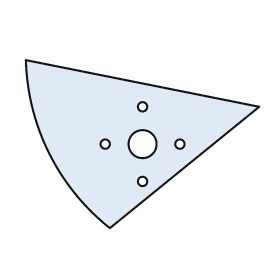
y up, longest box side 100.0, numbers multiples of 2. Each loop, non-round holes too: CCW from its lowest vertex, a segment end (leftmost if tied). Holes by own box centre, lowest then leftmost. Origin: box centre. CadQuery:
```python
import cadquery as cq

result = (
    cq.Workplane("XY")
    .moveTo(-14.0, -36.0)
    .lineTo(50.0, 16.0)
    .lineTo(-50.0, 36.0)
    .threePointArc((-40.0, -4.0), (-14.0, -36.0))
    .close()
    .moveTo(0.0, -16.0)
    .circle(2.0)
    .moveTo(-16.0, 0.0)
    .circle(2.0)
    .moveTo(0.0, 0.0)
    .circle(6.0)
    .moveTo(16.0, 0.0)
    .circle(2.0)
    .moveTo(0.0, 16.0)
    .circle(2.0)
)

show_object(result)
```